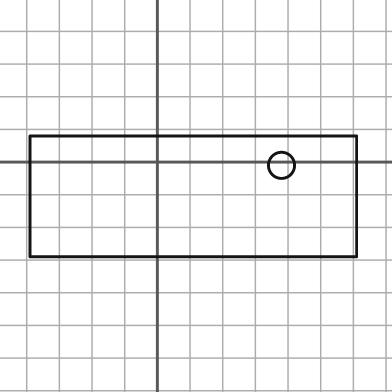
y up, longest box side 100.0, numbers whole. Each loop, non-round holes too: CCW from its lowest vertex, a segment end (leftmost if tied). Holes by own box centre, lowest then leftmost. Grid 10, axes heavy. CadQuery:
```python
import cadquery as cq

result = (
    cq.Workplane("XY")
    .moveTo(-39.0, -29.0)
    .lineTo(61.0, -29.0)
    .lineTo(61.0, 8.0)
    .lineTo(-39.0, 8.0)
    .close()
    .moveTo(38.0, -1.0)
    .circle(4.0)
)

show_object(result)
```